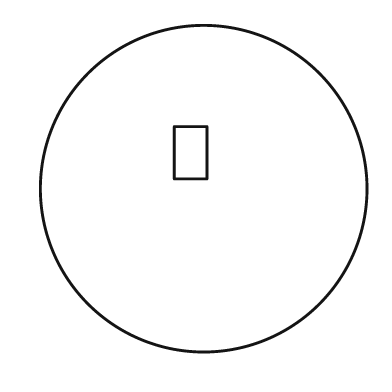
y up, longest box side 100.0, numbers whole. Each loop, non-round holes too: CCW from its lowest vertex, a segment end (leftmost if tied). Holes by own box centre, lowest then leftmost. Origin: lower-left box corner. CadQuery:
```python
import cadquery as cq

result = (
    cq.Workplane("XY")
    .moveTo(50.0, 50.0)
    .circle(50.0)
    .moveTo(41.0, 53.0)
    .lineTo(51.0, 53.0)
    .lineTo(51.0, 69.0)
    .lineTo(41.0, 69.0)
    .close()
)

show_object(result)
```